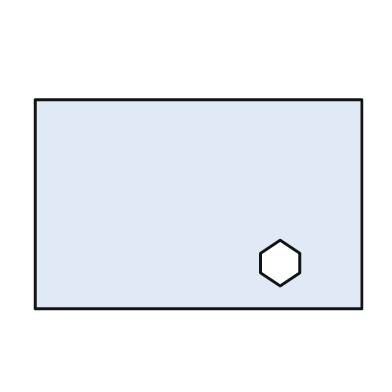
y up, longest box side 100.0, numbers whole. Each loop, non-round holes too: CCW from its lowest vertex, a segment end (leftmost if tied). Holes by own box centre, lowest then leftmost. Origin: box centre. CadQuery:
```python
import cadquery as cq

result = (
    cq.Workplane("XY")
    .moveTo(-50.0, -32.0)
    .lineTo(50.0, -32.0)
    .lineTo(50.0, 32.0)
    .lineTo(-50.0, 32.0)
    .close()
    .moveTo(25.0, -25.0)
    .lineTo(31.0, -21.0)
    .lineTo(31.0, -15.0)
    .lineTo(25.0, -11.0)
    .lineTo(19.0, -15.0)
    .lineTo(19.0, -21.0)
    .close()
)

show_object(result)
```